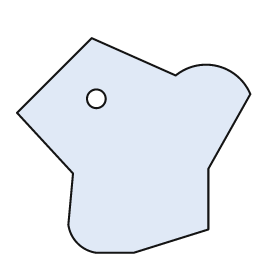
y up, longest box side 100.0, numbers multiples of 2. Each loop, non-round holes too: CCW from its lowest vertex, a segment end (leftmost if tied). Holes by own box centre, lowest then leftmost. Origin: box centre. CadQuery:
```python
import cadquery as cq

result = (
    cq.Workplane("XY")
    .moveTo(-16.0, -46.0)
    .lineTo(0.0, -46.0)
    .lineTo(32.0, -36.0)
    .lineTo(32.0, -10.0)
    .lineTo(50.0, 22.0)
    .threePointArc((36.0, 34.0), (18.0, 30.0))
    .lineTo(-18.0, 46.0)
    .lineTo(-50.0, 14.0)
    .lineTo(-26.0, -12.0)
    .lineTo(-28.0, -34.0)
    .threePointArc((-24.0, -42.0), (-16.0, -46.0))
    .close()
    .moveTo(-16.0, 20.0)
    .circle(4.0)
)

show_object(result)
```